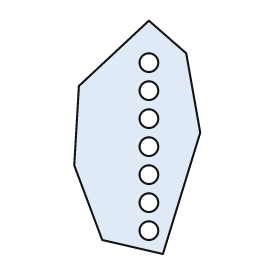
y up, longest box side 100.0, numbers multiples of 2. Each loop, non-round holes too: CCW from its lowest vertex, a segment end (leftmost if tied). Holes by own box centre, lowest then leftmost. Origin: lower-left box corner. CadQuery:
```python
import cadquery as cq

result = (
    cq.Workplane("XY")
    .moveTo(38.0, 0.0)
    .lineTo(54.0, 52.0)
    .lineTo(48.0, 86.0)
    .lineTo(32.0, 100.0)
    .lineTo(2.0, 72.0)
    .lineTo(0.0, 38.0)
    .lineTo(12.0, 6.0)
    .close()
    .moveTo(32.0, 10.0)
    .circle(4.0)
    .moveTo(32.0, 22.0)
    .circle(4.0)
    .moveTo(32.0, 34.0)
    .circle(4.0)
    .moveTo(32.0, 46.0)
    .circle(4.0)
    .moveTo(32.0, 58.0)
    .circle(4.0)
    .moveTo(32.0, 70.0)
    .circle(4.0)
    .moveTo(32.0, 82.0)
    .circle(4.0)
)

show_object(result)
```